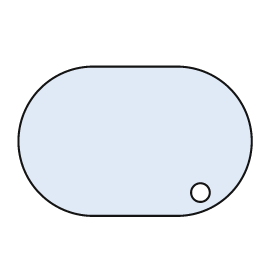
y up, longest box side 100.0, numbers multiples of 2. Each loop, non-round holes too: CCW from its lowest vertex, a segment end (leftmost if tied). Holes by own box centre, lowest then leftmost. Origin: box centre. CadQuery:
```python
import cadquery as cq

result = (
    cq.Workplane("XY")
    .moveTo(-18.0, -32.0)
    .lineTo(18.0, -32.0)
    .threePointArc((50.0, 0.0), (18.0, 32.0))
    .lineTo(-18.0, 32.0)
    .threePointArc((-50.0, 0.0), (-18.0, -32.0))
    .close()
    .moveTo(28.0, -22.0)
    .circle(4.0)
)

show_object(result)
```